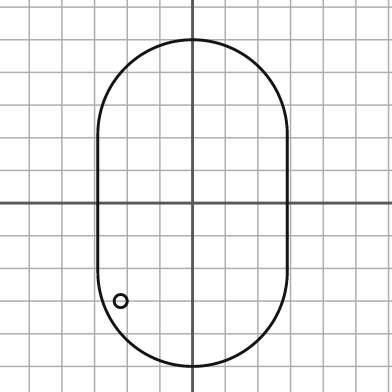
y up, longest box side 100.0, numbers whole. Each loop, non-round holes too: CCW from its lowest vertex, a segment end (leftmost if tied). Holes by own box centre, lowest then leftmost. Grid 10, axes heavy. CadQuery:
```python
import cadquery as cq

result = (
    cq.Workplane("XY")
    .moveTo(-29.0, -21.0)
    .threePointArc((0.0, -50.0), (29.0, -21.0))
    .lineTo(29.0, 21.0)
    .threePointArc((0.0, 50.0), (-29.0, 21.0))
    .close()
    .moveTo(-22.0, -30.0)
    .circle(2.0)
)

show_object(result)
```